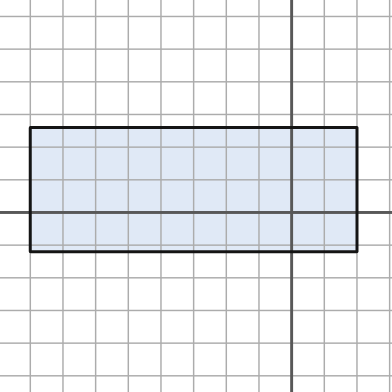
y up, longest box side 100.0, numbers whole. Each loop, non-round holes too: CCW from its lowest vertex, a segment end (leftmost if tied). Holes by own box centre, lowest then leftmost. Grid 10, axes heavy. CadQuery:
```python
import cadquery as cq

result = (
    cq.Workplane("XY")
    .moveTo(-80.0, -12.0)
    .lineTo(20.0, -12.0)
    .lineTo(20.0, 26.0)
    .lineTo(-80.0, 26.0)
    .close()
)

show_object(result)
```